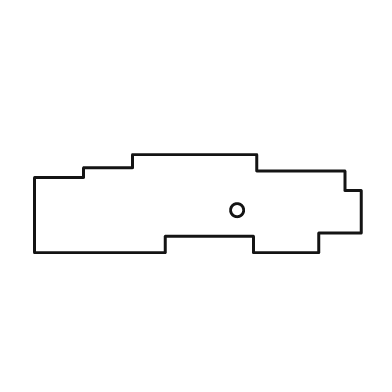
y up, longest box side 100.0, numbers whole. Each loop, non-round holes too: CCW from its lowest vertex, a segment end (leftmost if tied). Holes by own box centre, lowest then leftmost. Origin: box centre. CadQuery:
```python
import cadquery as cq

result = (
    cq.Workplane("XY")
    .moveTo(-50.0, -15.0)
    .lineTo(-10.0, -15.0)
    .lineTo(-10.0, -10.0)
    .lineTo(17.0, -10.0)
    .lineTo(17.0, -15.0)
    .lineTo(37.0, -15.0)
    .lineTo(37.0, -9.0)
    .lineTo(50.0, -9.0)
    .lineTo(50.0, 4.0)
    .lineTo(45.0, 4.0)
    .lineTo(45.0, 10.0)
    .lineTo(18.0, 10.0)
    .lineTo(18.0, 15.0)
    .lineTo(-20.0, 15.0)
    .lineTo(-20.0, 11.0)
    .lineTo(-35.0, 11.0)
    .lineTo(-35.0, 8.0)
    .lineTo(-50.0, 8.0)
    .close()
    .moveTo(12.0, -2.0)
    .circle(2.0)
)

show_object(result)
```